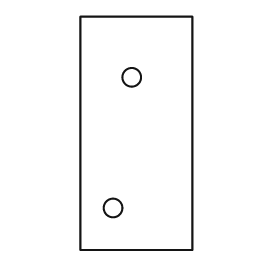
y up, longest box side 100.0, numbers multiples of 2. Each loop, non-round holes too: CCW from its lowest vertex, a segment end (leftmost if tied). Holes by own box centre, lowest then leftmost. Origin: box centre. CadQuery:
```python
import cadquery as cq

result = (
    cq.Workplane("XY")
    .moveTo(-24.0, -50.0)
    .lineTo(24.0, -50.0)
    .lineTo(24.0, 50.0)
    .lineTo(-24.0, 50.0)
    .close()
    .moveTo(-10.0, -32.0)
    .circle(4.0)
    .moveTo(-2.0, 24.0)
    .circle(4.0)
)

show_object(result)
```